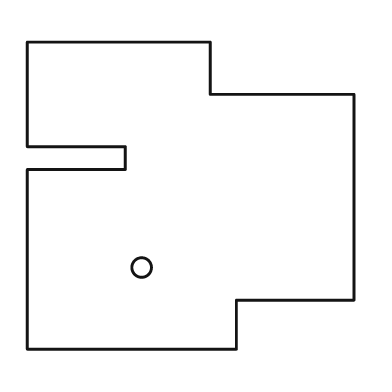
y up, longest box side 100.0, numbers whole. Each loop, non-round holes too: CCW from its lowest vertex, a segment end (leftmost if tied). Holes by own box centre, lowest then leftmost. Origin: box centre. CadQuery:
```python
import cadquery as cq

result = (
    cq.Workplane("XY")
    .moveTo(-50.0, -47.0)
    .lineTo(14.0, -47.0)
    .lineTo(14.0, -32.0)
    .lineTo(50.0, -32.0)
    .lineTo(50.0, 31.0)
    .lineTo(6.0, 31.0)
    .lineTo(6.0, 47.0)
    .lineTo(-50.0, 47.0)
    .lineTo(-50.0, 15.0)
    .lineTo(-20.0, 15.0)
    .lineTo(-20.0, 8.0)
    .lineTo(-50.0, 8.0)
    .close()
    .moveTo(-15.0, -22.0)
    .circle(3.0)
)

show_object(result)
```